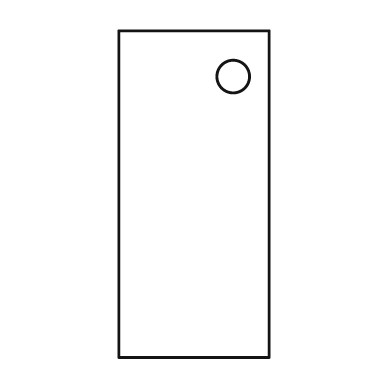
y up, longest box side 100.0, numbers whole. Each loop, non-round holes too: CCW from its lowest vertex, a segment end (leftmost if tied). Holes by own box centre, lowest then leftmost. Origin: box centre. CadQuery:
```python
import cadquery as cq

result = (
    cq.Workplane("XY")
    .moveTo(-23.0, -50.0)
    .lineTo(23.0, -50.0)
    .lineTo(23.0, 50.0)
    .lineTo(-23.0, 50.0)
    .close()
    .moveTo(12.0, 36.0)
    .circle(5.0)
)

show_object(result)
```